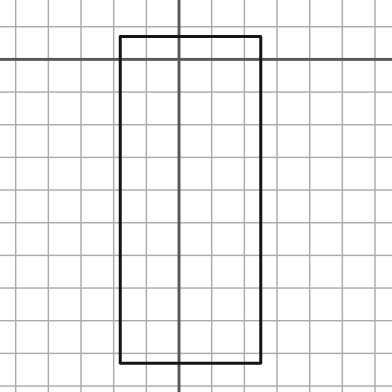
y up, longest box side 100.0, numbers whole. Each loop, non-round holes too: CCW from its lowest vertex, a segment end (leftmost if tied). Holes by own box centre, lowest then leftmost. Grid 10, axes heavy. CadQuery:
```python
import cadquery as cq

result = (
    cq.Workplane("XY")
    .moveTo(-18.0, -93.0)
    .lineTo(25.0, -93.0)
    .lineTo(25.0, 7.0)
    .lineTo(-18.0, 7.0)
    .close()
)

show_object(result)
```